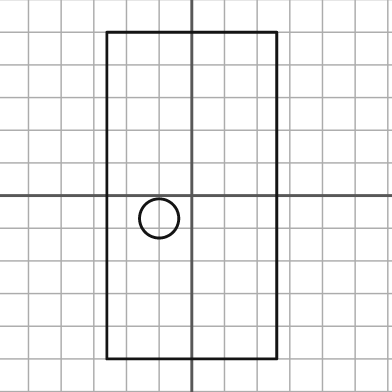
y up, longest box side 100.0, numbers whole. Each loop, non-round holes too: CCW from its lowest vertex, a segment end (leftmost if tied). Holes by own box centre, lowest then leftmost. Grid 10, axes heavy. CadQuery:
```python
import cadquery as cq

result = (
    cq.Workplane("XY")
    .moveTo(-26.0, -50.0)
    .lineTo(26.0, -50.0)
    .lineTo(26.0, 50.0)
    .lineTo(-26.0, 50.0)
    .close()
    .moveTo(-10.0, -7.0)
    .circle(6.0)
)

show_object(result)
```